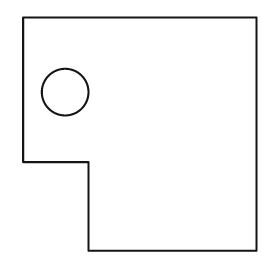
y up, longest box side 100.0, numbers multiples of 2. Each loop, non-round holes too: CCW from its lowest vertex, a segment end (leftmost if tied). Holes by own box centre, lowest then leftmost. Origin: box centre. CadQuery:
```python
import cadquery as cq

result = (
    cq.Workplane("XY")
    .moveTo(-22.0, -50.0)
    .lineTo(50.0, -50.0)
    .lineTo(50.0, 50.0)
    .lineTo(-50.0, 50.0)
    .lineTo(-50.0, -12.0)
    .lineTo(-22.0, -12.0)
    .close()
    .moveTo(-32.0, 18.0)
    .circle(10.0)
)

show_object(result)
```